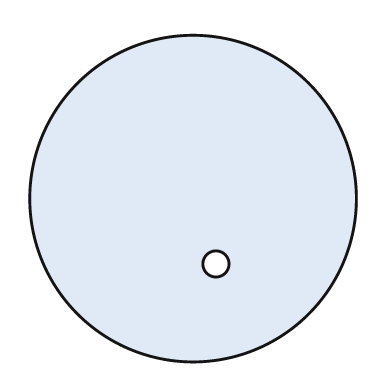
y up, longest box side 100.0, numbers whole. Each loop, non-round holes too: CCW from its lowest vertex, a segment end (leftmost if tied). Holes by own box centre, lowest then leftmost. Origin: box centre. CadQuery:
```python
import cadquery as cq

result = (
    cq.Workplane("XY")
    .moveTo(0.0, 0.0)
    .circle(50.0)
    .moveTo(7.0, -20.0)
    .circle(4.0)
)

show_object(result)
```